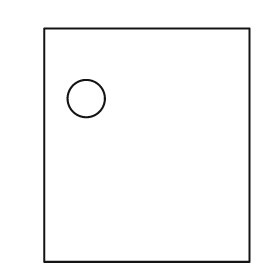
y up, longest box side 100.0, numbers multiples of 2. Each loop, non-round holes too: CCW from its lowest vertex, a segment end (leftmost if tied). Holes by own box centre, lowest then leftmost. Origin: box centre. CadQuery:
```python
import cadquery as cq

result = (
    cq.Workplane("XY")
    .moveTo(-44.0, -50.0)
    .lineTo(44.0, -50.0)
    .lineTo(44.0, 50.0)
    .lineTo(-44.0, 50.0)
    .close()
    .moveTo(-26.0, 20.0)
    .circle(8.0)
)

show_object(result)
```